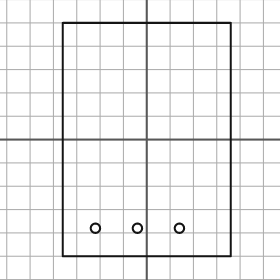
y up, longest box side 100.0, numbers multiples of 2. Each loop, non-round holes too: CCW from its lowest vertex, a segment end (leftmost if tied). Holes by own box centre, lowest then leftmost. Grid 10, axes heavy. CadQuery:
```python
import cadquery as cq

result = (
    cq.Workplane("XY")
    .moveTo(-36.0, -50.0)
    .lineTo(36.0, -50.0)
    .lineTo(36.0, 50.0)
    .lineTo(-36.0, 50.0)
    .close()
    .moveTo(-22.0, -38.0)
    .circle(2.0)
    .moveTo(-4.0, -38.0)
    .circle(2.0)
    .moveTo(14.0, -38.0)
    .circle(2.0)
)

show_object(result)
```